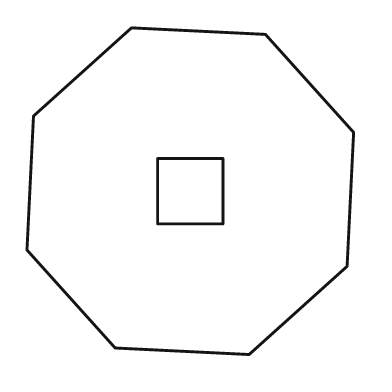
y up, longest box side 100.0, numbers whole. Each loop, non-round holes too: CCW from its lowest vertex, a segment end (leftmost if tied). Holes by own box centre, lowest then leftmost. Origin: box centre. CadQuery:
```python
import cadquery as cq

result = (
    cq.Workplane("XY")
    .moveTo(18.0, -50.0)
    .lineTo(48.0, -23.0)
    .lineTo(50.0, 18.0)
    .lineTo(23.0, 48.0)
    .lineTo(-18.0, 50.0)
    .lineTo(-48.0, 23.0)
    .lineTo(-50.0, -18.0)
    .lineTo(-23.0, -48.0)
    .close()
    .moveTo(-10.0, -10.0)
    .lineTo(10.0, -10.0)
    .lineTo(10.0, 10.0)
    .lineTo(-10.0, 10.0)
    .close()
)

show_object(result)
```